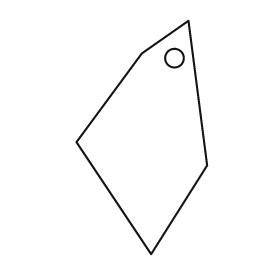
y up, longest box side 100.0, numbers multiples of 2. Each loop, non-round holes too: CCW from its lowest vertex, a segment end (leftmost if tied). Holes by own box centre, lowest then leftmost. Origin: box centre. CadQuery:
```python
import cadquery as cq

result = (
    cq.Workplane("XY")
    .moveTo(4.0, -50.0)
    .lineTo(28.0, -12.0)
    .lineTo(20.0, 50.0)
    .lineTo(0.0, 36.0)
    .lineTo(-28.0, -2.0)
    .close()
    .moveTo(14.0, 34.0)
    .circle(4.0)
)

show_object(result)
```